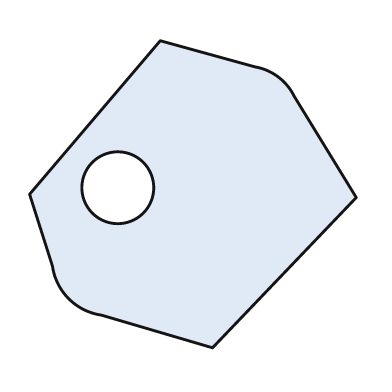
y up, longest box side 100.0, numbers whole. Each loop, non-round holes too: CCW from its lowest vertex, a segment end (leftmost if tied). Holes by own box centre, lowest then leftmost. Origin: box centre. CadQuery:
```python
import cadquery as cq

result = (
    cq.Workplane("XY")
    .moveTo(6.0, -47.0)
    .lineTo(50.0, -1.0)
    .lineTo(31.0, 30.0)
    .threePointArc((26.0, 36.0), (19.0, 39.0))
    .lineTo(-10.0, 47.0)
    .lineTo(-50.0, 0.0)
    .lineTo(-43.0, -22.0)
    .threePointArc((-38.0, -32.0), (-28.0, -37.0))
    .close()
    .moveTo(-23.0, 2.0)
    .circle(11.0)
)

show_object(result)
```